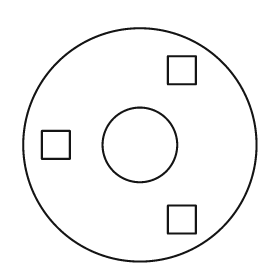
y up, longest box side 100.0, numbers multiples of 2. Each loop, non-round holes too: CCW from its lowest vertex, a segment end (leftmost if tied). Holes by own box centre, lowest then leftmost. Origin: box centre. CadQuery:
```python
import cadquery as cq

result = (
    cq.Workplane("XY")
    .moveTo(0.0, 0.0)
    .circle(50.0)
    .moveTo(12.0, -38.0)
    .lineTo(24.0, -38.0)
    .lineTo(24.0, -26.0)
    .lineTo(12.0, -26.0)
    .close()
    .moveTo(-42.0, -6.0)
    .lineTo(-30.0, -6.0)
    .lineTo(-30.0, 6.0)
    .lineTo(-42.0, 6.0)
    .close()
    .moveTo(0.0, 0.0)
    .circle(16.0)
    .moveTo(12.0, 26.0)
    .lineTo(24.0, 26.0)
    .lineTo(24.0, 38.0)
    .lineTo(12.0, 38.0)
    .close()
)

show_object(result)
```